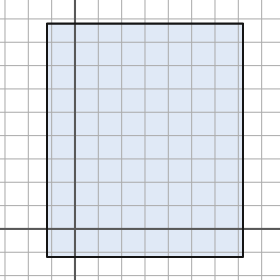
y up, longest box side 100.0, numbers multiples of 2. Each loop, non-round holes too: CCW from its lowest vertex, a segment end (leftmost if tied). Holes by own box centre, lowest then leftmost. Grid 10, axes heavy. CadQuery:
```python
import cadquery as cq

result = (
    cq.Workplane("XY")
    .moveTo(-12.0, -12.0)
    .lineTo(72.0, -12.0)
    .lineTo(72.0, 88.0)
    .lineTo(-12.0, 88.0)
    .close()
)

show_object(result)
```